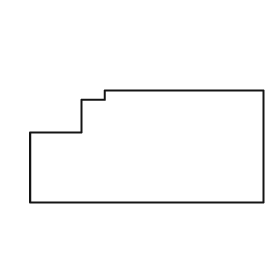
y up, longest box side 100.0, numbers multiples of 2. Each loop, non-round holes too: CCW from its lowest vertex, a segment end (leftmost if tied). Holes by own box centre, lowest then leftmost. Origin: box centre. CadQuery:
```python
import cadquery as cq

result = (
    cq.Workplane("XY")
    .moveTo(-50.0, -24.0)
    .lineTo(50.0, -24.0)
    .lineTo(50.0, 24.0)
    .lineTo(-18.0, 24.0)
    .lineTo(-18.0, 20.0)
    .lineTo(-28.0, 20.0)
    .lineTo(-28.0, 6.0)
    .lineTo(-50.0, 6.0)
    .close()
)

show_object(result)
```